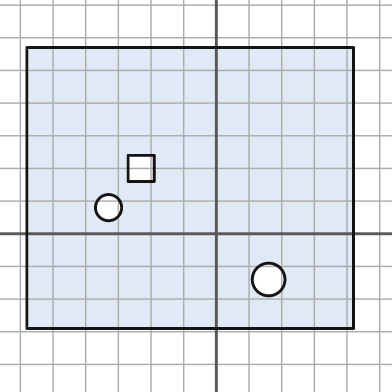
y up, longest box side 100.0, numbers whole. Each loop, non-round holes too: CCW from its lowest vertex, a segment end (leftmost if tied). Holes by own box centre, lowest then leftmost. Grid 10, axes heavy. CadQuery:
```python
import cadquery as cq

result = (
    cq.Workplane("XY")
    .moveTo(-58.0, -29.0)
    .lineTo(42.0, -29.0)
    .lineTo(42.0, 57.0)
    .lineTo(-58.0, 57.0)
    .close()
    .moveTo(16.0, -14.0)
    .circle(5.0)
    .moveTo(-33.0, 8.0)
    .circle(4.0)
    .moveTo(-27.0, 16.0)
    .lineTo(-19.0, 16.0)
    .lineTo(-19.0, 24.0)
    .lineTo(-27.0, 24.0)
    .close()
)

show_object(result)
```